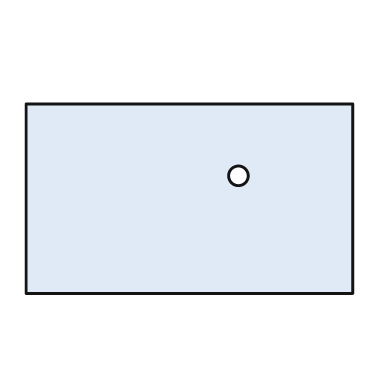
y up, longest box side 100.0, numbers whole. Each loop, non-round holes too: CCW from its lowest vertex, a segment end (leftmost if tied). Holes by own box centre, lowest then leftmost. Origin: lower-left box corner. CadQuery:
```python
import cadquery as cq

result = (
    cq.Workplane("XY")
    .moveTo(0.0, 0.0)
    .lineTo(100.0, 0.0)
    .lineTo(100.0, 58.0)
    .lineTo(0.0, 58.0)
    .close()
    .moveTo(65.0, 36.0)
    .circle(3.0)
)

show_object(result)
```